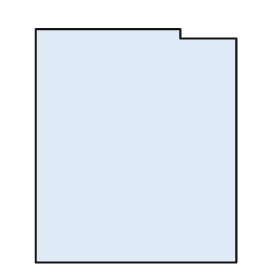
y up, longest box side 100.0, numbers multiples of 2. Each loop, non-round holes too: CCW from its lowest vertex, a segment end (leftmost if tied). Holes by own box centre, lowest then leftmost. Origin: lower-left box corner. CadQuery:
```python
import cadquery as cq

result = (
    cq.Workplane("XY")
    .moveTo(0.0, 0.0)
    .lineTo(86.0, 0.0)
    .lineTo(86.0, 96.0)
    .lineTo(62.0, 96.0)
    .lineTo(62.0, 100.0)
    .lineTo(0.0, 100.0)
    .close()
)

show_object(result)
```